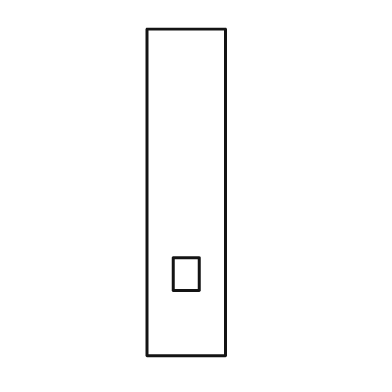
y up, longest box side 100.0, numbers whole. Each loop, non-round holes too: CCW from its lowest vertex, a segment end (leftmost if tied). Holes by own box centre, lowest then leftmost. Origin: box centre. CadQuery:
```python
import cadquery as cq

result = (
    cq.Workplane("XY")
    .moveTo(-12.0, -50.0)
    .lineTo(12.0, -50.0)
    .lineTo(12.0, 50.0)
    .lineTo(-12.0, 50.0)
    .close()
    .moveTo(-4.0, -30.0)
    .lineTo(4.0, -30.0)
    .lineTo(4.0, -20.0)
    .lineTo(-4.0, -20.0)
    .close()
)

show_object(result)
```